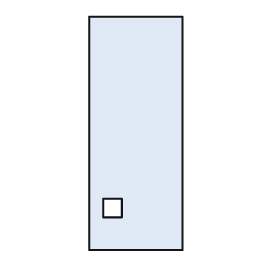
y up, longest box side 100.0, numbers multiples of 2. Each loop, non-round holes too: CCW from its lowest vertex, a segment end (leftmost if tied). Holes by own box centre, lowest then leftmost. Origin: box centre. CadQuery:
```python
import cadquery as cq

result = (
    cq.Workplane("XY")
    .moveTo(-20.0, -50.0)
    .lineTo(20.0, -50.0)
    .lineTo(20.0, 50.0)
    .lineTo(-20.0, 50.0)
    .close()
    .moveTo(-14.0, -36.0)
    .lineTo(-6.0, -36.0)
    .lineTo(-6.0, -28.0)
    .lineTo(-14.0, -28.0)
    .close()
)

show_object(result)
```